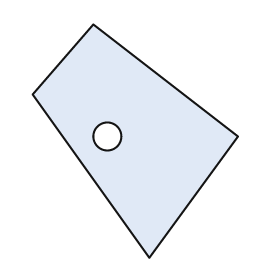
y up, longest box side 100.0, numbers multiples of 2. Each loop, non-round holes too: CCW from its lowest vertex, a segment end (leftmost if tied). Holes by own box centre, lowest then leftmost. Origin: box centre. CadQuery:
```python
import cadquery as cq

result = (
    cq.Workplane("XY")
    .moveTo(6.0, -50.0)
    .lineTo(44.0, 2.0)
    .lineTo(-18.0, 50.0)
    .lineTo(-44.0, 20.0)
    .close()
    .moveTo(-12.0, 2.0)
    .circle(6.0)
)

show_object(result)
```